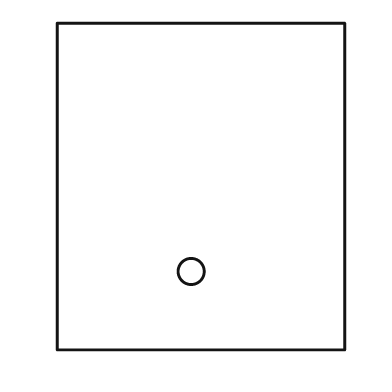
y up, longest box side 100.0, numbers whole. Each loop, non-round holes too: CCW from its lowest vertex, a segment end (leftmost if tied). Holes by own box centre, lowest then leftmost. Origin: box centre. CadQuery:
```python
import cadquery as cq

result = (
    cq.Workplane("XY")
    .moveTo(-44.0, -50.0)
    .lineTo(44.0, -50.0)
    .lineTo(44.0, 50.0)
    .lineTo(-44.0, 50.0)
    .close()
    .moveTo(-3.0, -26.0)
    .circle(4.0)
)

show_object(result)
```